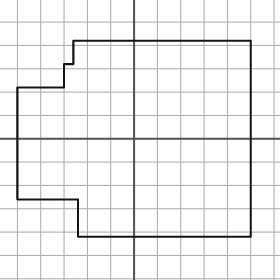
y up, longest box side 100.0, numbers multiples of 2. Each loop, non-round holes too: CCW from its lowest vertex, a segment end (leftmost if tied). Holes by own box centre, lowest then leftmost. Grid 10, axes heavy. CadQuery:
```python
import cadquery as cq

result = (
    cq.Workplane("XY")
    .moveTo(-24.0, -42.0)
    .lineTo(50.0, -42.0)
    .lineTo(50.0, 42.0)
    .lineTo(-26.0, 42.0)
    .lineTo(-26.0, 32.0)
    .lineTo(-30.0, 32.0)
    .lineTo(-30.0, 22.0)
    .lineTo(-50.0, 22.0)
    .lineTo(-50.0, -26.0)
    .lineTo(-24.0, -26.0)
    .close()
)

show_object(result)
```